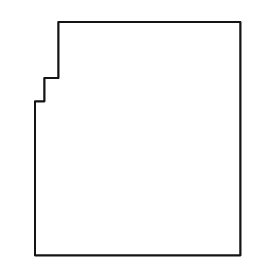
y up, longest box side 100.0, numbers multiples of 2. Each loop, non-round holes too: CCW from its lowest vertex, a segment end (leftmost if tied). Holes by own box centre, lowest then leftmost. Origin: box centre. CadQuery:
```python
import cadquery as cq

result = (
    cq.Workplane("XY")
    .moveTo(-44.0, -50.0)
    .lineTo(44.0, -50.0)
    .lineTo(44.0, 50.0)
    .lineTo(-34.0, 50.0)
    .lineTo(-34.0, 26.0)
    .lineTo(-40.0, 26.0)
    .lineTo(-40.0, 16.0)
    .lineTo(-44.0, 16.0)
    .close()
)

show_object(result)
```